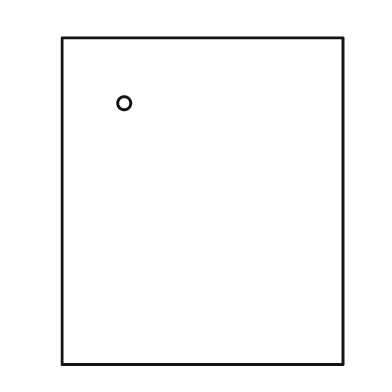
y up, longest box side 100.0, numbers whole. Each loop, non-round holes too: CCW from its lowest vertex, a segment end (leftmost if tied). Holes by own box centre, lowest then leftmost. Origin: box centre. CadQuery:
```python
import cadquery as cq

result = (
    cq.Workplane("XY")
    .moveTo(-43.0, -50.0)
    .lineTo(43.0, -50.0)
    .lineTo(43.0, 50.0)
    .lineTo(-43.0, 50.0)
    .close()
    .moveTo(-24.0, 30.0)
    .circle(2.0)
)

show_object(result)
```